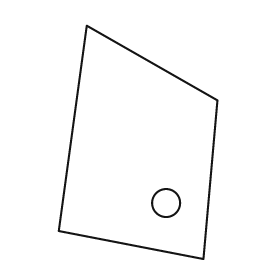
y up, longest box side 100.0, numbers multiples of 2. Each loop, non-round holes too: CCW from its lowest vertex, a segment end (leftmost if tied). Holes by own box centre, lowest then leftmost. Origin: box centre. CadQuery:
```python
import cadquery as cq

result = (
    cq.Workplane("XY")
    .moveTo(28.0, -50.0)
    .lineTo(34.0, 18.0)
    .lineTo(-22.0, 50.0)
    .lineTo(-34.0, -38.0)
    .close()
    .moveTo(12.0, -26.0)
    .circle(6.0)
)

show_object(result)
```